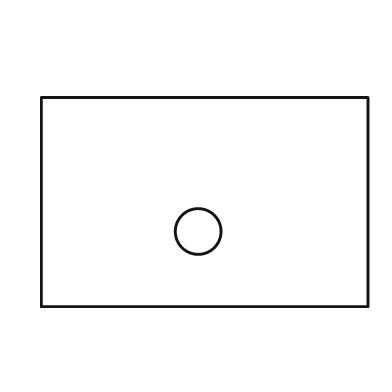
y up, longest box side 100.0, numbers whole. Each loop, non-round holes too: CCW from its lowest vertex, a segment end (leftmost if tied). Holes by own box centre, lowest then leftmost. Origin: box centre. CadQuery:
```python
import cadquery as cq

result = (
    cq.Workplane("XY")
    .moveTo(-50.0, -32.0)
    .lineTo(50.0, -32.0)
    .lineTo(50.0, 32.0)
    .lineTo(-50.0, 32.0)
    .close()
    .moveTo(-2.0, -9.0)
    .circle(7.0)
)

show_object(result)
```